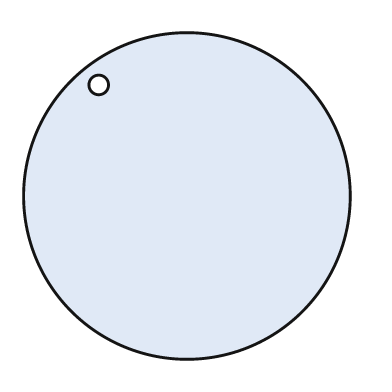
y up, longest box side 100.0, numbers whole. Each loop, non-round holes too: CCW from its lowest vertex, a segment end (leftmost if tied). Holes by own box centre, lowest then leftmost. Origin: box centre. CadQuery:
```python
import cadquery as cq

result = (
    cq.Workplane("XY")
    .moveTo(0.0, 0.0)
    .circle(50.0)
    .moveTo(-27.0, 34.0)
    .circle(3.0)
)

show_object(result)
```